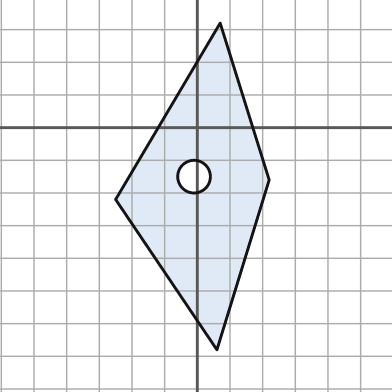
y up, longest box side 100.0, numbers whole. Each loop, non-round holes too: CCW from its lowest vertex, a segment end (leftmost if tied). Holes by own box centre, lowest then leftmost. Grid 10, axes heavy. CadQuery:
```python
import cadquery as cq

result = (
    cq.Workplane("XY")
    .moveTo(6.0, -68.0)
    .lineTo(22.0, -16.0)
    .lineTo(7.0, 32.0)
    .lineTo(-25.0, -22.0)
    .close()
    .moveTo(-1.0, -15.0)
    .circle(5.0)
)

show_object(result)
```